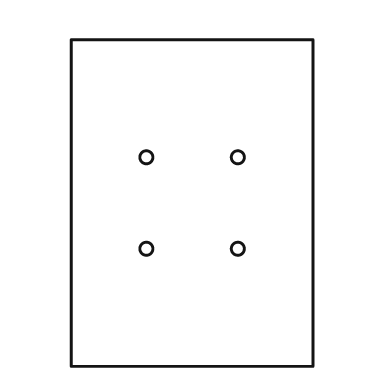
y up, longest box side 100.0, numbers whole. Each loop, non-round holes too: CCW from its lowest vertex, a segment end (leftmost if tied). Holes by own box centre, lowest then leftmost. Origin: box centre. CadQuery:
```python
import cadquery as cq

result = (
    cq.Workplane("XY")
    .moveTo(-37.0, -50.0)
    .lineTo(37.0, -50.0)
    .lineTo(37.0, 50.0)
    .lineTo(-37.0, 50.0)
    .close()
    .moveTo(-14.0, -14.0)
    .circle(2.0)
    .moveTo(14.0, -14.0)
    .circle(2.0)
    .moveTo(-14.0, 14.0)
    .circle(2.0)
    .moveTo(14.0, 14.0)
    .circle(2.0)
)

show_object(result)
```